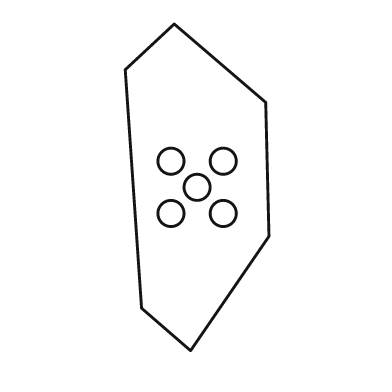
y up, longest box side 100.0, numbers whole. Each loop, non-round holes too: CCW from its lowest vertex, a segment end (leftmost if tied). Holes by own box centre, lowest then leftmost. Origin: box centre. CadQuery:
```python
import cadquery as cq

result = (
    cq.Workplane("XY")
    .moveTo(-2.0, -50.0)
    .lineTo(22.0, -15.0)
    .lineTo(21.0, 26.0)
    .lineTo(-7.0, 50.0)
    .lineTo(-22.0, 36.0)
    .lineTo(-17.0, -37.0)
    .close()
    .moveTo(-8.0, -8.0)
    .circle(4.0)
    .moveTo(8.0, -8.0)
    .circle(4.0)
    .moveTo(0.0, 0.0)
    .circle(4.0)
    .moveTo(-8.0, 8.0)
    .circle(4.0)
    .moveTo(8.0, 8.0)
    .circle(4.0)
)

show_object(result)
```